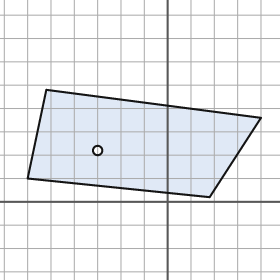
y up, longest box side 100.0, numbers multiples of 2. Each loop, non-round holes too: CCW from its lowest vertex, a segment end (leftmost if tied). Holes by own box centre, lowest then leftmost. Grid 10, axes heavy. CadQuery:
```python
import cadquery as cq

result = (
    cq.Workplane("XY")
    .moveTo(18.0, 2.0)
    .lineTo(40.0, 36.0)
    .lineTo(-52.0, 48.0)
    .lineTo(-60.0, 10.0)
    .close()
    .moveTo(-30.0, 22.0)
    .circle(2.0)
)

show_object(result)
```